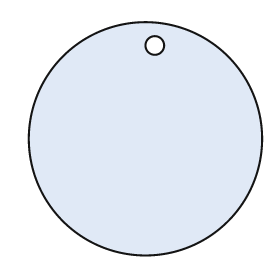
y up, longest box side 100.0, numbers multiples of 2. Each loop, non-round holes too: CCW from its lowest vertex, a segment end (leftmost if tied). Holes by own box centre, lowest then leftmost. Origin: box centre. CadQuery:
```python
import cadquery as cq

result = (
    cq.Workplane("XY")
    .moveTo(0.0, 0.0)
    .circle(50.0)
    .moveTo(4.0, 40.0)
    .circle(4.0)
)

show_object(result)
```